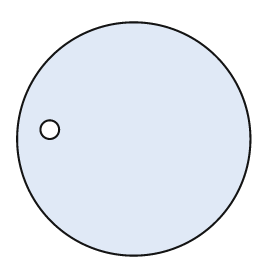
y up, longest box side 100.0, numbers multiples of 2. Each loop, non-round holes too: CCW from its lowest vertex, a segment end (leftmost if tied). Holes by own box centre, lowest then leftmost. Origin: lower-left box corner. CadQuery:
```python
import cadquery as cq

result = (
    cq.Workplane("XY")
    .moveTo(50.0, 50.0)
    .circle(50.0)
    .moveTo(14.0, 54.0)
    .circle(4.0)
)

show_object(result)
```